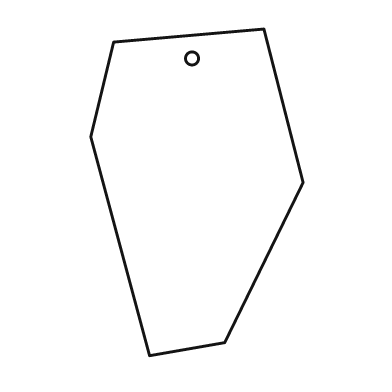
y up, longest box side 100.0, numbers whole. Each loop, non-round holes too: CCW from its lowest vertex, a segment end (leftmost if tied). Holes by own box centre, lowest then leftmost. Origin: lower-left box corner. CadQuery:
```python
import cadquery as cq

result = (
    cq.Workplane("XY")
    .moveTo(18.0, 0.0)
    .lineTo(41.0, 4.0)
    .lineTo(65.0, 53.0)
    .lineTo(53.0, 100.0)
    .lineTo(7.0, 96.0)
    .lineTo(0.0, 67.0)
    .close()
    .moveTo(31.0, 91.0)
    .circle(2.0)
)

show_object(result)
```